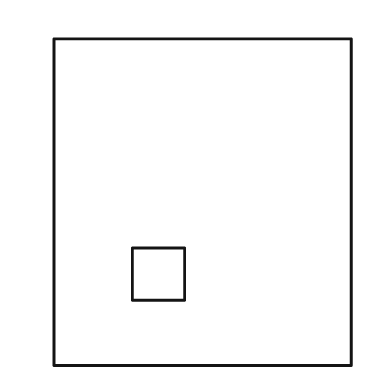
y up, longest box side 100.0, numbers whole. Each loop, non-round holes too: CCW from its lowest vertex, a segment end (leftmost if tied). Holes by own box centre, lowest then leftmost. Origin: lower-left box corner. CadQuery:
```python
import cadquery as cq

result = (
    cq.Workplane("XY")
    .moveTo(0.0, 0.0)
    .lineTo(91.0, 0.0)
    .lineTo(91.0, 100.0)
    .lineTo(0.0, 100.0)
    .close()
    .moveTo(24.0, 20.0)
    .lineTo(40.0, 20.0)
    .lineTo(40.0, 36.0)
    .lineTo(24.0, 36.0)
    .close()
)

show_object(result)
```